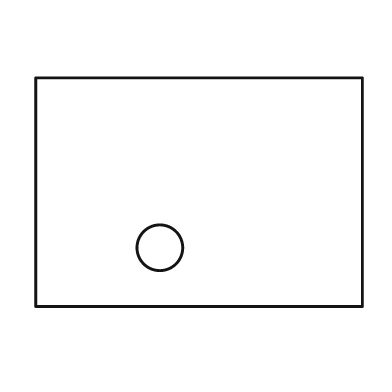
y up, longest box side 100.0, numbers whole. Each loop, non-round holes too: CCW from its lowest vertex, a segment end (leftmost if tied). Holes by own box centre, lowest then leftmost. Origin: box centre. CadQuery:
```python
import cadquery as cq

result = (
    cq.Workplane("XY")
    .moveTo(-50.0, -35.0)
    .lineTo(50.0, -35.0)
    .lineTo(50.0, 35.0)
    .lineTo(-50.0, 35.0)
    .close()
    .moveTo(-12.0, -17.0)
    .circle(7.0)
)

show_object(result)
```